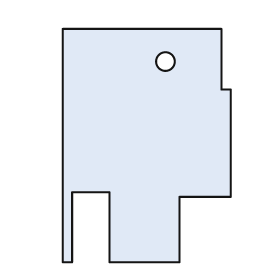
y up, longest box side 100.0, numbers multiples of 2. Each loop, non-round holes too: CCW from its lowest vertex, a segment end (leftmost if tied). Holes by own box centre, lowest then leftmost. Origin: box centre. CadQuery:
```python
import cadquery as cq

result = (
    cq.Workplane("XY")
    .moveTo(-36.0, -50.0)
    .lineTo(-32.0, -50.0)
    .lineTo(-32.0, -20.0)
    .lineTo(-16.0, -20.0)
    .lineTo(-16.0, -50.0)
    .lineTo(14.0, -50.0)
    .lineTo(14.0, -22.0)
    .lineTo(36.0, -22.0)
    .lineTo(36.0, 24.0)
    .lineTo(32.0, 24.0)
    .lineTo(32.0, 50.0)
    .lineTo(-36.0, 50.0)
    .close()
    .moveTo(8.0, 36.0)
    .circle(4.0)
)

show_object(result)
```